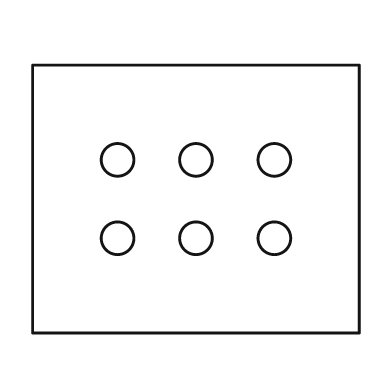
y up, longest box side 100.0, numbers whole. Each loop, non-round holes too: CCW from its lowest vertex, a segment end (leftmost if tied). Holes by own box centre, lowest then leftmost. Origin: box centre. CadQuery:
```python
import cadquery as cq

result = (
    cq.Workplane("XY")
    .moveTo(-50.0, -41.0)
    .lineTo(50.0, -41.0)
    .lineTo(50.0, 41.0)
    .lineTo(-50.0, 41.0)
    .close()
    .moveTo(-24.0, -12.0)
    .circle(5.0)
    .moveTo(0.0, -12.0)
    .circle(5.0)
    .moveTo(24.0, -12.0)
    .circle(5.0)
    .moveTo(-24.0, 12.0)
    .circle(5.0)
    .moveTo(0.0, 12.0)
    .circle(5.0)
    .moveTo(24.0, 12.0)
    .circle(5.0)
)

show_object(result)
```